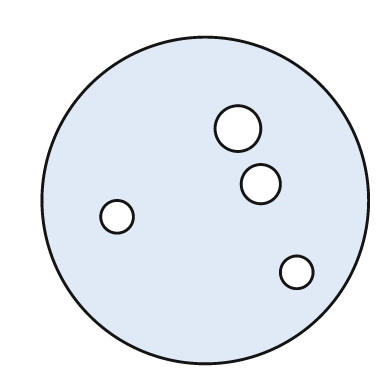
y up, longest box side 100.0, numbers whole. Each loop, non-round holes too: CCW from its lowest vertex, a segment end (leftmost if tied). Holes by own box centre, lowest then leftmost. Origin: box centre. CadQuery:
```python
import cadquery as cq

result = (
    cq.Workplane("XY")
    .moveTo(0.0, 0.0)
    .circle(50.0)
    .moveTo(28.0, -22.0)
    .circle(5.0)
    .moveTo(-27.0, -5.0)
    .circle(5.0)
    .moveTo(17.0, 5.0)
    .circle(6.0)
    .moveTo(10.0, 22.0)
    .circle(7.0)
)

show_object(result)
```